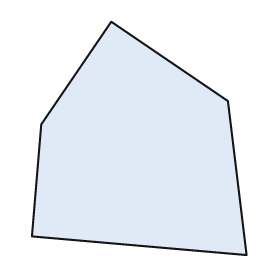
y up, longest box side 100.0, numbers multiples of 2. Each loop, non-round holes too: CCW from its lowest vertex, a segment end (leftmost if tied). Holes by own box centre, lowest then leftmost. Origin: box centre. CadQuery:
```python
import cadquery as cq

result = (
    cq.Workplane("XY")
    .moveTo(46.0, -50.0)
    .lineTo(38.0, 16.0)
    .lineTo(-12.0, 50.0)
    .lineTo(-42.0, 6.0)
    .lineTo(-46.0, -42.0)
    .close()
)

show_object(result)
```